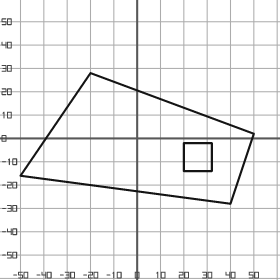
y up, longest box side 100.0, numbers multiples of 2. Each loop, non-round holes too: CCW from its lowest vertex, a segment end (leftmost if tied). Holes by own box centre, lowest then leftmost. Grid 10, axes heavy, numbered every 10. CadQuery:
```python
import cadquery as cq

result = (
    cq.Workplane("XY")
    .moveTo(40.0, -28.0)
    .lineTo(50.0, 2.0)
    .lineTo(-20.0, 28.0)
    .lineTo(-50.0, -16.0)
    .close()
    .moveTo(20.0, -14.0)
    .lineTo(32.0, -14.0)
    .lineTo(32.0, -2.0)
    .lineTo(20.0, -2.0)
    .close()
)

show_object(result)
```